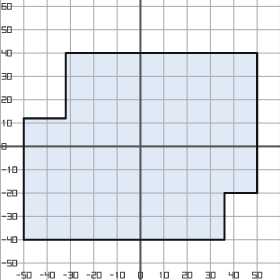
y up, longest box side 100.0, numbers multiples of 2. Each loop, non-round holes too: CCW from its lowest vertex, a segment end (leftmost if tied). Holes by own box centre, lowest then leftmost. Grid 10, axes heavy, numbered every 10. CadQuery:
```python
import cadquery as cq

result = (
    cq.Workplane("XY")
    .moveTo(-50.0, -40.0)
    .lineTo(36.0, -40.0)
    .lineTo(36.0, -20.0)
    .lineTo(50.0, -20.0)
    .lineTo(50.0, 40.0)
    .lineTo(-32.0, 40.0)
    .lineTo(-32.0, 12.0)
    .lineTo(-50.0, 12.0)
    .close()
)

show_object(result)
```